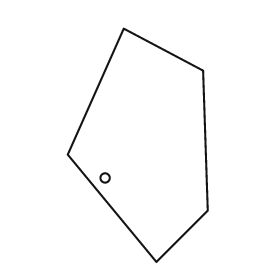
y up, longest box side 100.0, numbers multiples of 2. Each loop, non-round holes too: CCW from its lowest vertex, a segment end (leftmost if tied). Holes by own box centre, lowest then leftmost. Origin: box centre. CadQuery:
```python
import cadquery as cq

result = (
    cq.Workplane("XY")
    .moveTo(8.0, -50.0)
    .lineTo(30.0, -28.0)
    .lineTo(28.0, 32.0)
    .lineTo(-6.0, 50.0)
    .lineTo(-30.0, -4.0)
    .close()
    .moveTo(-14.0, -14.0)
    .circle(2.0)
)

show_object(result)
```